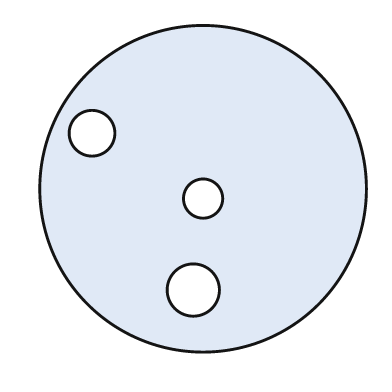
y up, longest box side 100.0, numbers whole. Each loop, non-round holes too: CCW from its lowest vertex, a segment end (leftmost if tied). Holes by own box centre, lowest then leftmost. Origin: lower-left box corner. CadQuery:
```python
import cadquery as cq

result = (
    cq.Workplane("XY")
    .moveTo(50.0, 50.0)
    .circle(50.0)
    .moveTo(47.0, 19.0)
    .circle(8.0)
    .moveTo(50.0, 47.0)
    .circle(6.0)
    .moveTo(16.0, 67.0)
    .circle(7.0)
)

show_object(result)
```